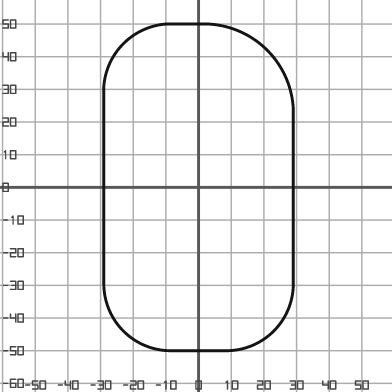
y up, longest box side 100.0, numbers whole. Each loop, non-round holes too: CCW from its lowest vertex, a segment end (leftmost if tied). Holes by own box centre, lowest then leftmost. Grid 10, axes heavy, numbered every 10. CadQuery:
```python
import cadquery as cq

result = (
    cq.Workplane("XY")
    .moveTo(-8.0, -50.0)
    .lineTo(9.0, -50.0)
    .threePointArc((23.0, -44.0), (29.0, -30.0))
    .lineTo(29.0, 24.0)
    .threePointArc((21.0, 42.0), (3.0, 50.0))
    .lineTo(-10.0, 50.0)
    .threePointArc((-23.0, 44.0), (-29.0, 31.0))
    .lineTo(-29.0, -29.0)
    .threePointArc((-23.0, -44.0), (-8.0, -50.0))
    .close()
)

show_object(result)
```